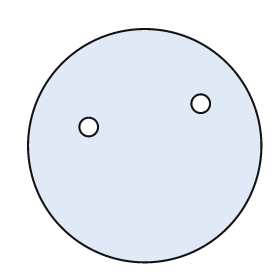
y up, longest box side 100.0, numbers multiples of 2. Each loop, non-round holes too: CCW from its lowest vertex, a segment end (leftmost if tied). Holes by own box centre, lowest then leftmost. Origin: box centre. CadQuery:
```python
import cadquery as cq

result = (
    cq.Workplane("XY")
    .moveTo(0.0, 0.0)
    .circle(50.0)
    .moveTo(-24.0, 8.0)
    .circle(4.0)
    .moveTo(24.0, 18.0)
    .circle(4.0)
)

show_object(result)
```